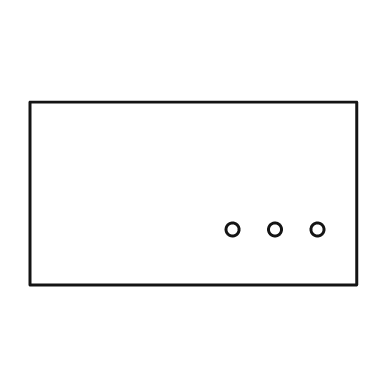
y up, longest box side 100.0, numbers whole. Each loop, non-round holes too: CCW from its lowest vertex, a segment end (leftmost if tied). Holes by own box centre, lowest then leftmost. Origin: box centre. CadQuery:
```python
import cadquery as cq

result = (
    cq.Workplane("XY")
    .moveTo(-50.0, -28.0)
    .lineTo(50.0, -28.0)
    .lineTo(50.0, 28.0)
    .lineTo(-50.0, 28.0)
    .close()
    .moveTo(12.0, -11.0)
    .circle(2.0)
    .moveTo(25.0, -11.0)
    .circle(2.0)
    .moveTo(38.0, -11.0)
    .circle(2.0)
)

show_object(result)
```